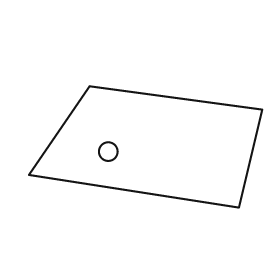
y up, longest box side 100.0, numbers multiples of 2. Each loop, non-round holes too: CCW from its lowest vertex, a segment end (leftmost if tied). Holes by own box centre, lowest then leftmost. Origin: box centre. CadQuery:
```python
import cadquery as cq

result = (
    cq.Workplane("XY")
    .moveTo(40.0, -26.0)
    .lineTo(50.0, 16.0)
    .lineTo(-24.0, 26.0)
    .lineTo(-50.0, -12.0)
    .close()
    .moveTo(-16.0, -2.0)
    .circle(4.0)
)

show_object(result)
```